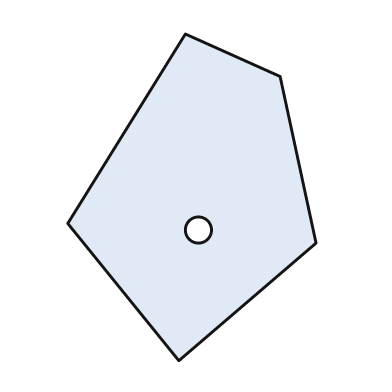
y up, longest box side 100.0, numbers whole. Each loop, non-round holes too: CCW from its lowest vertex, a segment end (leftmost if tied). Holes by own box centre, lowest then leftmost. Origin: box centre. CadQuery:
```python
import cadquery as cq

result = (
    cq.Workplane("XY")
    .moveTo(-4.0, -50.0)
    .lineTo(38.0, -14.0)
    .lineTo(27.0, 37.0)
    .lineTo(-2.0, 50.0)
    .lineTo(-38.0, -8.0)
    .close()
    .moveTo(2.0, -10.0)
    .circle(4.0)
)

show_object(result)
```